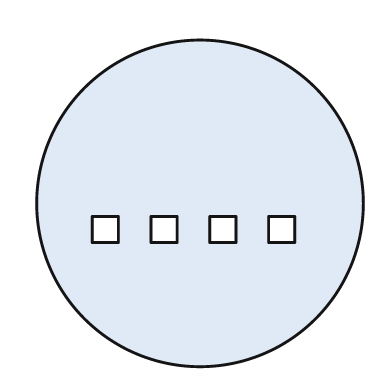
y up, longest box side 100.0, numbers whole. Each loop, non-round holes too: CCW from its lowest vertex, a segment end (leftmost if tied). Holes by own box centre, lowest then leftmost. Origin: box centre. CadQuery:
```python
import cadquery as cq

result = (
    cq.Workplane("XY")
    .moveTo(0.0, 0.0)
    .circle(50.0)
    .moveTo(-33.0, -12.0)
    .lineTo(-25.0, -12.0)
    .lineTo(-25.0, -4.0)
    .lineTo(-33.0, -4.0)
    .close()
    .moveTo(-15.0, -12.0)
    .lineTo(-7.0, -12.0)
    .lineTo(-7.0, -4.0)
    .lineTo(-15.0, -4.0)
    .close()
    .moveTo(3.0, -12.0)
    .lineTo(11.0, -12.0)
    .lineTo(11.0, -4.0)
    .lineTo(3.0, -4.0)
    .close()
    .moveTo(21.0, -12.0)
    .lineTo(29.0, -12.0)
    .lineTo(29.0, -4.0)
    .lineTo(21.0, -4.0)
    .close()
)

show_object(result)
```